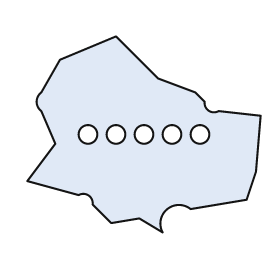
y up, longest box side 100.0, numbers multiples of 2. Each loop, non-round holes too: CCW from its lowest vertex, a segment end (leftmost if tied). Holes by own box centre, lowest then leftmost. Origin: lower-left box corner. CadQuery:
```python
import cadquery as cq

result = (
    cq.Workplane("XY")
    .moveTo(58.0, 0.0)
    .threePointArc((60.0, 10.0), (70.0, 10.0))
    .lineTo(94.0, 14.0)
    .lineTo(98.0, 26.0)
    .lineTo(100.0, 50.0)
    .lineTo(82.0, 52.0)
    .threePointArc((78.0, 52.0), (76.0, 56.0))
    .lineTo(72.0, 60.0)
    .lineTo(56.0, 66.0)
    .lineTo(38.0, 84.0)
    .lineTo(14.0, 74.0)
    .lineTo(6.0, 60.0)
    .threePointArc((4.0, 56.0), (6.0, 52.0))
    .lineTo(12.0, 38.0)
    .lineTo(0.0, 22.0)
    .lineTo(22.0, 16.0)
    .threePointArc((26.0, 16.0), (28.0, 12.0))
    .lineTo(36.0, 4.0)
    .lineTo(48.0, 6.0)
    .close()
    .moveTo(26.0, 42.0)
    .circle(4.0)
    .moveTo(38.0, 42.0)
    .circle(4.0)
    .moveTo(50.0, 42.0)
    .circle(4.0)
    .moveTo(62.0, 42.0)
    .circle(4.0)
    .moveTo(74.0, 42.0)
    .circle(4.0)
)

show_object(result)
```